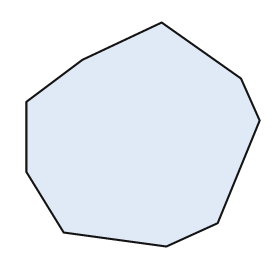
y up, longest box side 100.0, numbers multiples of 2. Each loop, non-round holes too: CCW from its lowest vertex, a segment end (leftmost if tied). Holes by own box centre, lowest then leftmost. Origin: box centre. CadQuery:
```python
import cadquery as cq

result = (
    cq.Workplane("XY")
    .moveTo(10.0, -48.0)
    .lineTo(32.0, -38.0)
    .lineTo(50.0, 6.0)
    .lineTo(42.0, 24.0)
    .lineTo(8.0, 48.0)
    .lineTo(-26.0, 32.0)
    .lineTo(-50.0, 14.0)
    .lineTo(-50.0, -16.0)
    .lineTo(-34.0, -42.0)
    .close()
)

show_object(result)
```